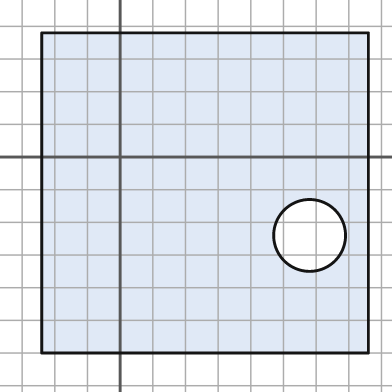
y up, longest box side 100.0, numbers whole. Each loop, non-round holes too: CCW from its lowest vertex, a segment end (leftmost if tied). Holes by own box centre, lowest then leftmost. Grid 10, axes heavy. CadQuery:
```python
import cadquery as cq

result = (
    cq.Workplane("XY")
    .moveTo(-24.0, -60.0)
    .lineTo(76.0, -60.0)
    .lineTo(76.0, 38.0)
    .lineTo(-24.0, 38.0)
    .close()
    .moveTo(58.0, -24.0)
    .circle(11.0)
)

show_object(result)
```